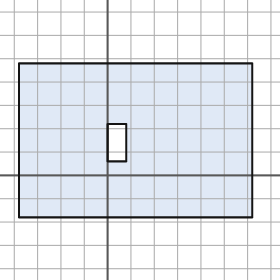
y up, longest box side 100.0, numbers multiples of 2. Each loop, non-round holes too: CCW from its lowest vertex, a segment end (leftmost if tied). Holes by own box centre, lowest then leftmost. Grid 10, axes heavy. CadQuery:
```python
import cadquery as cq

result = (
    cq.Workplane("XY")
    .moveTo(-38.0, -18.0)
    .lineTo(62.0, -18.0)
    .lineTo(62.0, 48.0)
    .lineTo(-38.0, 48.0)
    .close()
    .moveTo(0.0, 6.0)
    .lineTo(8.0, 6.0)
    .lineTo(8.0, 22.0)
    .lineTo(0.0, 22.0)
    .close()
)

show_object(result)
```